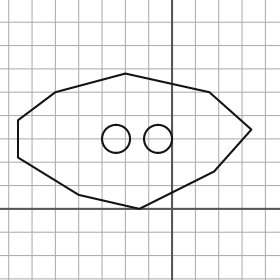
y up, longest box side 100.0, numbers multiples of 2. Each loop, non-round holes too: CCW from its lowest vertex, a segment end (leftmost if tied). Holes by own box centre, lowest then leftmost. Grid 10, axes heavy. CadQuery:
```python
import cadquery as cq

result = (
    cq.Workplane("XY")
    .moveTo(-14.0, 0.0)
    .lineTo(18.0, 16.0)
    .lineTo(34.0, 34.0)
    .lineTo(16.0, 50.0)
    .lineTo(-20.0, 58.0)
    .lineTo(-50.0, 50.0)
    .lineTo(-66.0, 38.0)
    .lineTo(-66.0, 22.0)
    .lineTo(-40.0, 6.0)
    .close()
    .moveTo(-24.0, 30.0)
    .circle(6.0)
    .moveTo(-6.0, 30.0)
    .circle(6.0)
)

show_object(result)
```